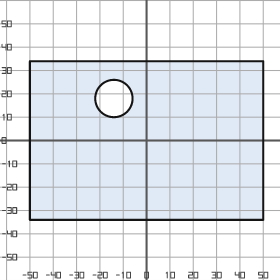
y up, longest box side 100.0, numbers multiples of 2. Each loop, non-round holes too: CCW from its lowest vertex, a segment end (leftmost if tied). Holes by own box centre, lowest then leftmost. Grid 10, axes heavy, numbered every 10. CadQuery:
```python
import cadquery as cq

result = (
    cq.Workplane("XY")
    .moveTo(-50.0, -34.0)
    .lineTo(50.0, -34.0)
    .lineTo(50.0, 34.0)
    .lineTo(-50.0, 34.0)
    .close()
    .moveTo(-14.0, 18.0)
    .circle(8.0)
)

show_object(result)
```